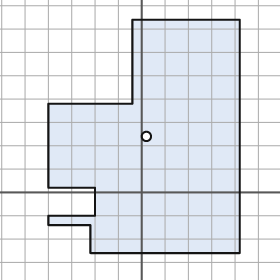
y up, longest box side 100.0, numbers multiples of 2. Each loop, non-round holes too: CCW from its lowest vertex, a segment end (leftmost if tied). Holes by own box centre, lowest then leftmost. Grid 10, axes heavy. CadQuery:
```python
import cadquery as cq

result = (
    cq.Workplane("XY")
    .moveTo(-22.0, -26.0)
    .lineTo(42.0, -26.0)
    .lineTo(42.0, 74.0)
    .lineTo(-4.0, 74.0)
    .lineTo(-4.0, 38.0)
    .lineTo(-40.0, 38.0)
    .lineTo(-40.0, 2.0)
    .lineTo(-20.0, 2.0)
    .lineTo(-20.0, -10.0)
    .lineTo(-40.0, -10.0)
    .lineTo(-40.0, -14.0)
    .lineTo(-22.0, -14.0)
    .close()
    .moveTo(2.0, 24.0)
    .circle(2.0)
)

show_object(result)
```